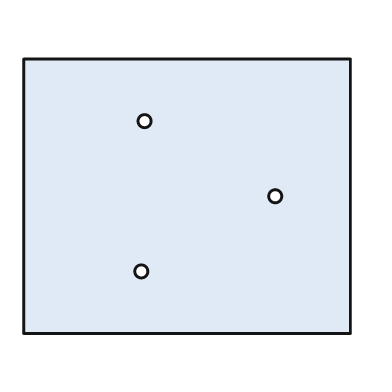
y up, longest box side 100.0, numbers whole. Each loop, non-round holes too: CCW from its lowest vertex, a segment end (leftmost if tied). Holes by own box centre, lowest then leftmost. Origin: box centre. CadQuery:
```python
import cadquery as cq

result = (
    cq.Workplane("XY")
    .moveTo(-50.0, -42.0)
    .lineTo(50.0, -42.0)
    .lineTo(50.0, 42.0)
    .lineTo(-50.0, 42.0)
    .close()
    .moveTo(-14.0, -23.0)
    .circle(2.0)
    .moveTo(27.0, 0.0)
    .circle(2.0)
    .moveTo(-13.0, 23.0)
    .circle(2.0)
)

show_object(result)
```